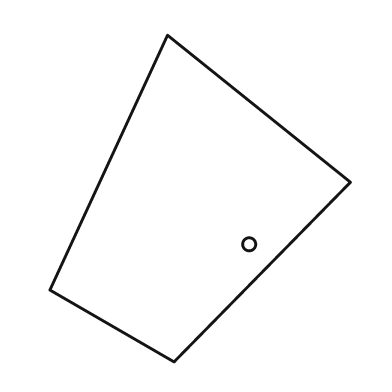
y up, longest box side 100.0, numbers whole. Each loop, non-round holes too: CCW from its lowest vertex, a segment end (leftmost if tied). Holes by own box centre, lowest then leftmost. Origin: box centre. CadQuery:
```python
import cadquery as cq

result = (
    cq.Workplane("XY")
    .moveTo(-8.0, -50.0)
    .lineTo(46.0, 5.0)
    .lineTo(-10.0, 50.0)
    .lineTo(-46.0, -28.0)
    .close()
    .moveTo(15.0, -14.0)
    .circle(2.0)
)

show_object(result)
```